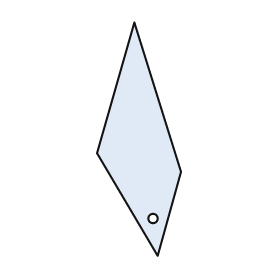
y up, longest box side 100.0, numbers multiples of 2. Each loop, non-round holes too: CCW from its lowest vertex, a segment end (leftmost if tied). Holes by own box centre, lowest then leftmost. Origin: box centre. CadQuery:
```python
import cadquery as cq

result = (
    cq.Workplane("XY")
    .moveTo(8.0, -50.0)
    .lineTo(18.0, -14.0)
    .lineTo(-2.0, 50.0)
    .lineTo(-18.0, -6.0)
    .close()
    .moveTo(6.0, -34.0)
    .circle(2.0)
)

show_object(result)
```